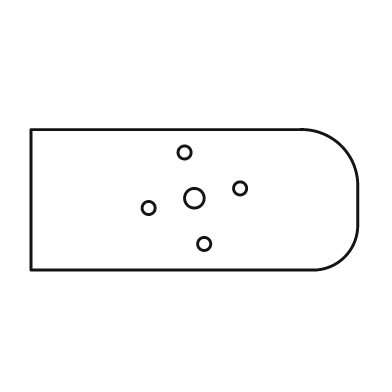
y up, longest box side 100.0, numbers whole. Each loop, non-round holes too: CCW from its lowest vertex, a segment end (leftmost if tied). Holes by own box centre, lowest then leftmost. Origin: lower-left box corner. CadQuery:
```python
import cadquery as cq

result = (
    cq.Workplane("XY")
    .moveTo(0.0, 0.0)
    .lineTo(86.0, 0.0)
    .threePointArc((96.0, 4.0), (100.0, 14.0))
    .lineTo(100.0, 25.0)
    .threePointArc((95.0, 38.0), (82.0, 43.0))
    .lineTo(0.0, 43.0)
    .close()
    .moveTo(53.0, 8.0)
    .circle(2.0)
    .moveTo(36.0, 19.0)
    .circle(2.0)
    .moveTo(50.0, 22.0)
    .circle(3.0)
    .moveTo(64.0, 25.0)
    .circle(2.0)
    .moveTo(47.0, 36.0)
    .circle(2.0)
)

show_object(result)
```